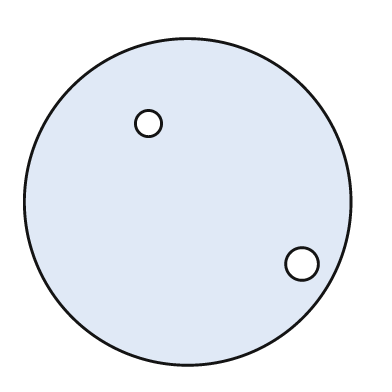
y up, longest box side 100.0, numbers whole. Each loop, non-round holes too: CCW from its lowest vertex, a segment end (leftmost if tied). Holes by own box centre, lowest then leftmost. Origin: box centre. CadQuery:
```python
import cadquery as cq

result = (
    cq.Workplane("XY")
    .moveTo(0.0, 0.0)
    .circle(50.0)
    .moveTo(35.0, -19.0)
    .circle(5.0)
    .moveTo(-12.0, 24.0)
    .circle(4.0)
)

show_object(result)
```